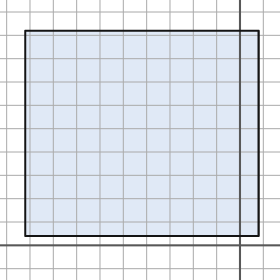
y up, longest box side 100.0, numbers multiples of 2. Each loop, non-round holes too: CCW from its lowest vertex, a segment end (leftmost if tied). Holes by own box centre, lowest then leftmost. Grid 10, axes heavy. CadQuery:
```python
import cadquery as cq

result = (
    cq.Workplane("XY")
    .moveTo(-92.0, 4.0)
    .lineTo(8.0, 4.0)
    .lineTo(8.0, 92.0)
    .lineTo(-92.0, 92.0)
    .close()
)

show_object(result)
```